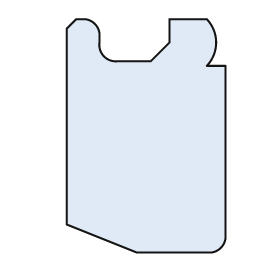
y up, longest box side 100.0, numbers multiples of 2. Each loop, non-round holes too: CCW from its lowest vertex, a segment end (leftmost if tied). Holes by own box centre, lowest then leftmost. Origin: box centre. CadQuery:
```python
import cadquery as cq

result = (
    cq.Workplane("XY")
    .moveTo(-4.0, -50.0)
    .lineTo(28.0, -50.0)
    .threePointArc((32.0, -48.0), (34.0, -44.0))
    .lineTo(34.0, 30.0)
    .lineTo(26.0, 30.0)
    .threePointArc((30.0, 40.0), (26.0, 50.0))
    .lineTo(10.0, 50.0)
    .lineTo(10.0, 40.0)
    .lineTo(2.0, 32.0)
    .lineTo(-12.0, 32.0)
    .threePointArc((-18.0, 34.0), (-20.0, 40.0))
    .lineTo(-20.0, 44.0)
    .threePointArc((-22.0, 48.0), (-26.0, 50.0))
    .lineTo(-30.0, 50.0)
    .lineTo(-34.0, 46.0)
    .lineTo(-34.0, -38.0)
    .close()
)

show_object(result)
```